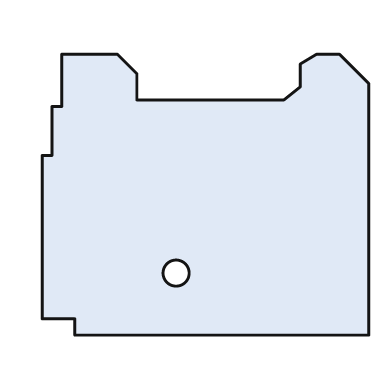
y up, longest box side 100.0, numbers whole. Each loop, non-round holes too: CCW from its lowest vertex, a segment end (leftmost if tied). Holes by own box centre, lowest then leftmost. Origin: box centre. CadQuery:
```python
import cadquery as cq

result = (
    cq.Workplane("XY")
    .moveTo(-40.0, -43.0)
    .lineTo(50.0, -43.0)
    .lineTo(50.0, 34.0)
    .lineTo(41.0, 43.0)
    .lineTo(34.0, 43.0)
    .lineTo(29.0, 40.0)
    .lineTo(29.0, 33.0)
    .lineTo(24.0, 29.0)
    .lineTo(-21.0, 29.0)
    .lineTo(-21.0, 37.0)
    .lineTo(-27.0, 43.0)
    .lineTo(-44.0, 43.0)
    .lineTo(-44.0, 27.0)
    .lineTo(-47.0, 27.0)
    .lineTo(-47.0, 12.0)
    .lineTo(-50.0, 12.0)
    .lineTo(-50.0, -38.0)
    .lineTo(-40.0, -38.0)
    .close()
    .moveTo(-9.0, -24.0)
    .circle(4.0)
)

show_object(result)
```